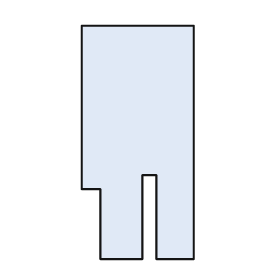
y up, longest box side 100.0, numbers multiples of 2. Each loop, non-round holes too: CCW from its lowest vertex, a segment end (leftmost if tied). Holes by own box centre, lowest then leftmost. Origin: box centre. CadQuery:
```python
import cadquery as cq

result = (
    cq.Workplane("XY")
    .moveTo(-16.0, -50.0)
    .lineTo(2.0, -50.0)
    .lineTo(2.0, -14.0)
    .lineTo(8.0, -14.0)
    .lineTo(8.0, -50.0)
    .lineTo(24.0, -50.0)
    .lineTo(24.0, 50.0)
    .lineTo(-24.0, 50.0)
    .lineTo(-24.0, -20.0)
    .lineTo(-16.0, -20.0)
    .close()
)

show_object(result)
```